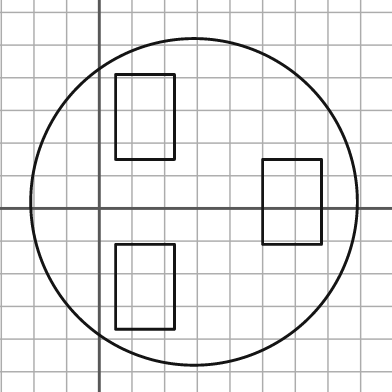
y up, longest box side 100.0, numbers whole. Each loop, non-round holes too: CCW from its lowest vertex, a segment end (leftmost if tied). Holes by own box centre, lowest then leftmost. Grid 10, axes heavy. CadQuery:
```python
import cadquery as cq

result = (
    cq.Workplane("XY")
    .moveTo(29.0, 2.0)
    .circle(50.0)
    .moveTo(5.0, -37.0)
    .lineTo(23.0, -37.0)
    .lineTo(23.0, -11.0)
    .lineTo(5.0, -11.0)
    .close()
    .moveTo(50.0, -11.0)
    .lineTo(68.0, -11.0)
    .lineTo(68.0, 15.0)
    .lineTo(50.0, 15.0)
    .close()
    .moveTo(5.0, 15.0)
    .lineTo(23.0, 15.0)
    .lineTo(23.0, 41.0)
    .lineTo(5.0, 41.0)
    .close()
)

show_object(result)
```